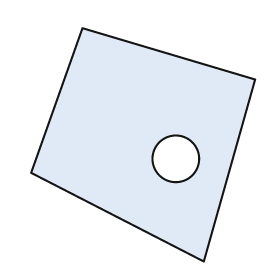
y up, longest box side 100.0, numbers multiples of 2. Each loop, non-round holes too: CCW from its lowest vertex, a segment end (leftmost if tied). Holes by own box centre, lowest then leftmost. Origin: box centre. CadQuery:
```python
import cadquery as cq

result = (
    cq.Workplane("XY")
    .moveTo(26.0, -50.0)
    .lineTo(48.0, 28.0)
    .lineTo(-26.0, 50.0)
    .lineTo(-48.0, -12.0)
    .close()
    .moveTo(14.0, -6.0)
    .circle(10.0)
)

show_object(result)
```